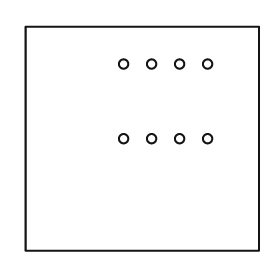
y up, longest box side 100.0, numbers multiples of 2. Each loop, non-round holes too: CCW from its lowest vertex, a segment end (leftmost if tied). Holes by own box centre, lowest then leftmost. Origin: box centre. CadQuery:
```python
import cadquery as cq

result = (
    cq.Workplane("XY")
    .moveTo(-50.0, -48.0)
    .lineTo(50.0, -48.0)
    .lineTo(50.0, 48.0)
    .lineTo(-50.0, 48.0)
    .close()
    .moveTo(-8.0, 0.0)
    .circle(2.0)
    .moveTo(4.0, 0.0)
    .circle(2.0)
    .moveTo(16.0, 0.0)
    .circle(2.0)
    .moveTo(28.0, 0.0)
    .circle(2.0)
    .moveTo(-8.0, 32.0)
    .circle(2.0)
    .moveTo(4.0, 32.0)
    .circle(2.0)
    .moveTo(16.0, 32.0)
    .circle(2.0)
    .moveTo(28.0, 32.0)
    .circle(2.0)
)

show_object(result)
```